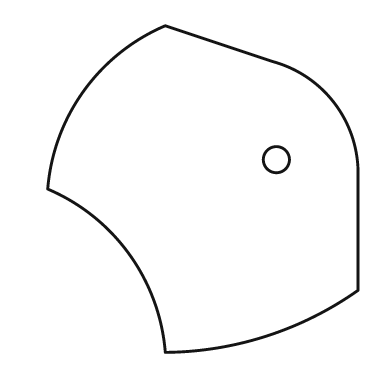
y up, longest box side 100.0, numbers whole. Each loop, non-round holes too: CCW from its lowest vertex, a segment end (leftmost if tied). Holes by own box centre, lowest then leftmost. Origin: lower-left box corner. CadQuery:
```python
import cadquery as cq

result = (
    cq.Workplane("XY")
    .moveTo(36.0, 0.0)
    .threePointArc((67.0, 5.0), (95.0, 19.0))
    .lineTo(95.0, 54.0)
    .threePointArc((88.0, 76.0), (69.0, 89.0))
    .lineTo(36.0, 100.0)
    .threePointArc((11.0, 80.0), (0.0, 50.0))
    .threePointArc((25.0, 30.0), (36.0, 0.0))
    .close()
    .moveTo(70.0, 59.0)
    .circle(4.0)
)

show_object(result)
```